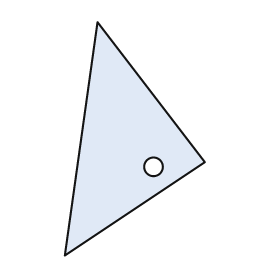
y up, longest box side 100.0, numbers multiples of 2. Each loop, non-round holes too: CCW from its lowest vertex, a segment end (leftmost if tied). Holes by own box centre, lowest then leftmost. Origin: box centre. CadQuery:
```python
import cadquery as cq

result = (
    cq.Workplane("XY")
    .moveTo(-30.0, -50.0)
    .lineTo(30.0, -10.0)
    .lineTo(-16.0, 50.0)
    .close()
    .moveTo(8.0, -12.0)
    .circle(4.0)
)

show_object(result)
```